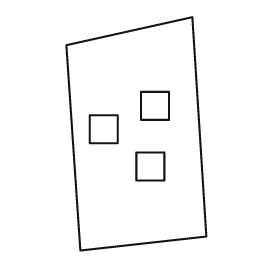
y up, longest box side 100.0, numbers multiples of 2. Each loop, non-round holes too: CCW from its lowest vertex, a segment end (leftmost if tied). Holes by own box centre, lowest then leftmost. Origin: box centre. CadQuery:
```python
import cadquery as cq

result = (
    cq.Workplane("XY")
    .moveTo(-24.0, -50.0)
    .lineTo(30.0, -44.0)
    .lineTo(24.0, 50.0)
    .lineTo(-30.0, 38.0)
    .close()
    .moveTo(0.0, -20.0)
    .lineTo(12.0, -20.0)
    .lineTo(12.0, -8.0)
    .lineTo(0.0, -8.0)
    .close()
    .moveTo(-20.0, -4.0)
    .lineTo(-8.0, -4.0)
    .lineTo(-8.0, 8.0)
    .lineTo(-20.0, 8.0)
    .close()
    .moveTo(2.0, 6.0)
    .lineTo(14.0, 6.0)
    .lineTo(14.0, 18.0)
    .lineTo(2.0, 18.0)
    .close()
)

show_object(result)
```